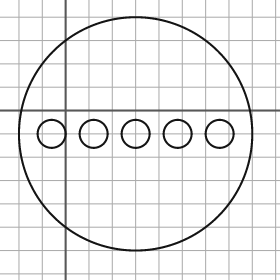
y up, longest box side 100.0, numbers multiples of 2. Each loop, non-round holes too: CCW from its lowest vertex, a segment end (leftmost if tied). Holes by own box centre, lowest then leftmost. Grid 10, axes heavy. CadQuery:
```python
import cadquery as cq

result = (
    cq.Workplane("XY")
    .moveTo(30.0, -10.0)
    .circle(50.0)
    .moveTo(-6.0, -10.0)
    .circle(6.0)
    .moveTo(12.0, -10.0)
    .circle(6.0)
    .moveTo(30.0, -10.0)
    .circle(6.0)
    .moveTo(48.0, -10.0)
    .circle(6.0)
    .moveTo(66.0, -10.0)
    .circle(6.0)
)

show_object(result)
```